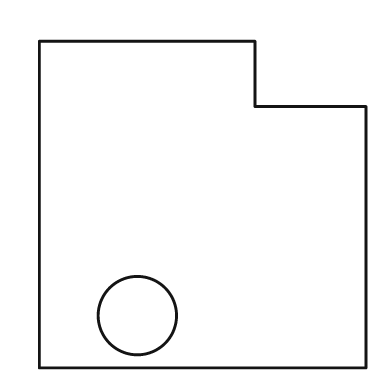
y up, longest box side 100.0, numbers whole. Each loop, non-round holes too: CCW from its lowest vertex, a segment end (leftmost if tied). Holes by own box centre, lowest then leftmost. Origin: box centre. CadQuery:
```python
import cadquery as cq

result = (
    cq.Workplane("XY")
    .moveTo(-50.0, -50.0)
    .lineTo(50.0, -50.0)
    .lineTo(50.0, 30.0)
    .lineTo(16.0, 30.0)
    .lineTo(16.0, 50.0)
    .lineTo(-50.0, 50.0)
    .close()
    .moveTo(-20.0, -34.0)
    .circle(12.0)
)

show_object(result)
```